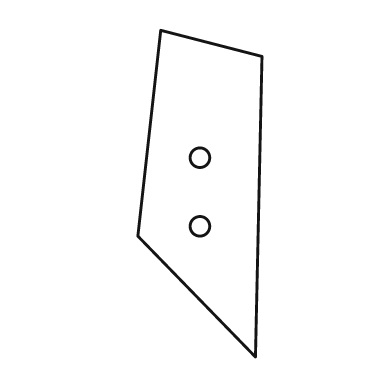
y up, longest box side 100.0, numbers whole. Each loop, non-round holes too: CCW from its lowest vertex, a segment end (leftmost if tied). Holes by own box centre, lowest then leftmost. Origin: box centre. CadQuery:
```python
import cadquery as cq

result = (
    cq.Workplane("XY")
    .moveTo(17.0, -50.0)
    .lineTo(19.0, 42.0)
    .lineTo(-12.0, 50.0)
    .lineTo(-19.0, -13.0)
    .close()
    .moveTo(0.0, -10.0)
    .circle(3.0)
    .moveTo(0.0, 11.0)
    .circle(3.0)
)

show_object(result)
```